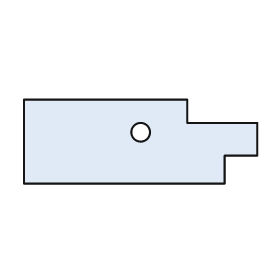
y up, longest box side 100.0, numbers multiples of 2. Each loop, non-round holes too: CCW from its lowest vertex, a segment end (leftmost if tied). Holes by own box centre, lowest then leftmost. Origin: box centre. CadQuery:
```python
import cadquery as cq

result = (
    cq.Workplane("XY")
    .moveTo(-50.0, -18.0)
    .lineTo(36.0, -18.0)
    .lineTo(36.0, -6.0)
    .lineTo(50.0, -6.0)
    .lineTo(50.0, 8.0)
    .lineTo(20.0, 8.0)
    .lineTo(20.0, 18.0)
    .lineTo(-50.0, 18.0)
    .close()
    .moveTo(0.0, 4.0)
    .circle(4.0)
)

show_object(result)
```